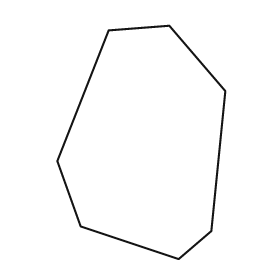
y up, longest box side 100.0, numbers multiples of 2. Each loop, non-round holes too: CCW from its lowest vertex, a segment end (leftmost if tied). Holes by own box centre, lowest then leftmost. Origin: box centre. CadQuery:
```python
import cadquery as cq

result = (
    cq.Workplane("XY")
    .moveTo(16.0, -50.0)
    .lineTo(30.0, -38.0)
    .lineTo(36.0, 22.0)
    .lineTo(12.0, 50.0)
    .lineTo(-14.0, 48.0)
    .lineTo(-36.0, -8.0)
    .lineTo(-26.0, -36.0)
    .close()
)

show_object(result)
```